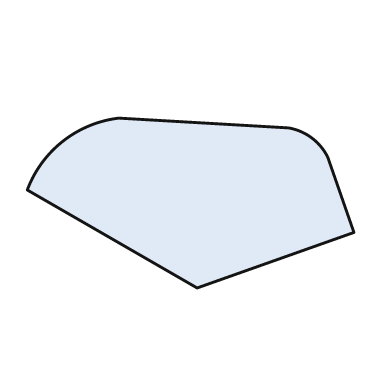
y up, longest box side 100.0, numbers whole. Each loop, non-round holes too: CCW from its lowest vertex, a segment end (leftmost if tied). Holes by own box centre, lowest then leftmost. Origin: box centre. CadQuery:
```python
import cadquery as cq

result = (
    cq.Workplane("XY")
    .moveTo(2.0, -26.0)
    .lineTo(50.0, -9.0)
    .lineTo(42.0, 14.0)
    .threePointArc((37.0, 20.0), (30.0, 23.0))
    .lineTo(-22.0, 26.0)
    .threePointArc((-39.0, 19.0), (-50.0, 4.0))
    .close()
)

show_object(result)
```